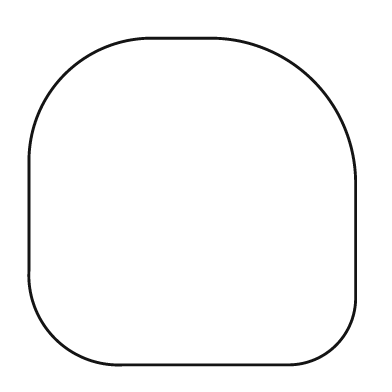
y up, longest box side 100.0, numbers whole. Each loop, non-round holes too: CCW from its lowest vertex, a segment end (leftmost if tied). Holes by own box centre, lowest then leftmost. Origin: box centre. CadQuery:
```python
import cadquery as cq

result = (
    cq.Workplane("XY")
    .moveTo(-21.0, -50.0)
    .lineTo(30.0, -50.0)
    .threePointArc((44.0, -44.0), (50.0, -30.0))
    .lineTo(50.0, 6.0)
    .threePointArc((37.0, 37.0), (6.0, 50.0))
    .lineTo(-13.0, 50.0)
    .threePointArc((-39.0, 39.0), (-50.0, 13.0))
    .lineTo(-50.0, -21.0)
    .threePointArc((-42.0, -42.0), (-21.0, -50.0))
    .close()
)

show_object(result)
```